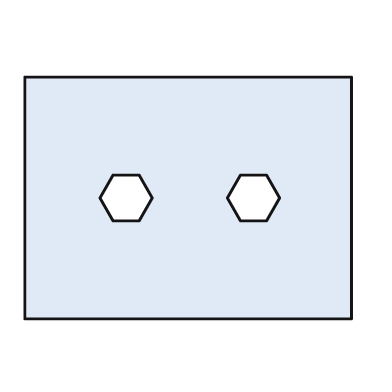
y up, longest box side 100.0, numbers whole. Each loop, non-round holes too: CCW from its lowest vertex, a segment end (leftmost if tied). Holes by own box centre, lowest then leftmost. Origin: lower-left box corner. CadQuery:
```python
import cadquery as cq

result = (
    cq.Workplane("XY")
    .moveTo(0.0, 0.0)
    .lineTo(100.0, 0.0)
    .lineTo(100.0, 74.0)
    .lineTo(0.0, 74.0)
    .close()
    .moveTo(27.0, 30.0)
    .lineTo(35.0, 30.0)
    .lineTo(39.0, 37.0)
    .lineTo(35.0, 44.0)
    .lineTo(27.0, 44.0)
    .lineTo(23.0, 37.0)
    .close()
    .moveTo(66.0, 30.0)
    .lineTo(74.0, 30.0)
    .lineTo(78.0, 37.0)
    .lineTo(74.0, 44.0)
    .lineTo(66.0, 44.0)
    .lineTo(62.0, 37.0)
    .close()
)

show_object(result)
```